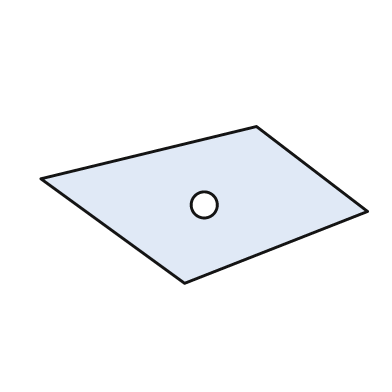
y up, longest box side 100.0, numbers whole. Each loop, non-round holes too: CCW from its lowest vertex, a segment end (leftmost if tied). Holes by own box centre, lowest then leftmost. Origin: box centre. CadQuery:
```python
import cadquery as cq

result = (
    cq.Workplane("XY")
    .moveTo(-6.0, -24.0)
    .lineTo(50.0, -2.0)
    .lineTo(16.0, 24.0)
    .lineTo(-50.0, 8.0)
    .close()
    .moveTo(0.0, 0.0)
    .circle(4.0)
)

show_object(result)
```